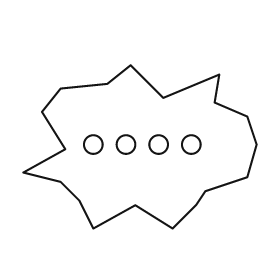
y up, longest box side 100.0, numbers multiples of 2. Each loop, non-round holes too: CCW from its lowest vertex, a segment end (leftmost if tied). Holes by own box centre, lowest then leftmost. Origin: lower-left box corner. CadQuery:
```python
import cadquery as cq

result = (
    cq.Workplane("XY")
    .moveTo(30.0, 0.0)
    .lineTo(48.0, 10.0)
    .lineTo(64.0, 0.0)
    .lineTo(74.0, 10.0)
    .lineTo(78.0, 16.0)
    .lineTo(96.0, 22.0)
    .lineTo(100.0, 36.0)
    .lineTo(96.0, 48.0)
    .lineTo(82.0, 54.0)
    .lineTo(84.0, 66.0)
    .lineTo(60.0, 56.0)
    .lineTo(46.0, 70.0)
    .lineTo(36.0, 62.0)
    .lineTo(16.0, 60.0)
    .lineTo(8.0, 50.0)
    .lineTo(18.0, 34.0)
    .lineTo(0.0, 24.0)
    .lineTo(16.0, 20.0)
    .lineTo(24.0, 12.0)
    .close()
    .moveTo(30.0, 36.0)
    .circle(4.0)
    .moveTo(44.0, 36.0)
    .circle(4.0)
    .moveTo(58.0, 36.0)
    .circle(4.0)
    .moveTo(72.0, 36.0)
    .circle(4.0)
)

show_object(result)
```